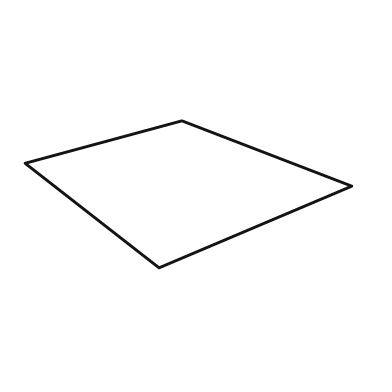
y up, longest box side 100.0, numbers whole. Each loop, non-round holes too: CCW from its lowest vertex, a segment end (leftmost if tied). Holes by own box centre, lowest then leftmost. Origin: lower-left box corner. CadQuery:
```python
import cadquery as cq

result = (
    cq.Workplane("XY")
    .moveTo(41.0, 0.0)
    .lineTo(100.0, 25.0)
    .lineTo(48.0, 45.0)
    .lineTo(0.0, 32.0)
    .close()
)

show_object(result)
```